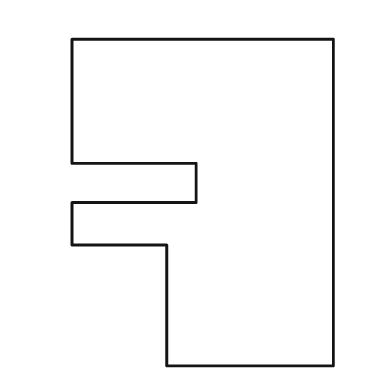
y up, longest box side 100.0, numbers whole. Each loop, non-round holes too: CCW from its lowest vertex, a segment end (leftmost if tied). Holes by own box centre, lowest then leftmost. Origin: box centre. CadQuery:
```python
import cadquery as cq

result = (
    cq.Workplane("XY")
    .moveTo(-11.0, -50.0)
    .lineTo(40.0, -50.0)
    .lineTo(40.0, 50.0)
    .lineTo(-40.0, 50.0)
    .lineTo(-40.0, 12.0)
    .lineTo(-2.0, 12.0)
    .lineTo(-2.0, 0.0)
    .lineTo(-40.0, 0.0)
    .lineTo(-40.0, -13.0)
    .lineTo(-11.0, -13.0)
    .close()
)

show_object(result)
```